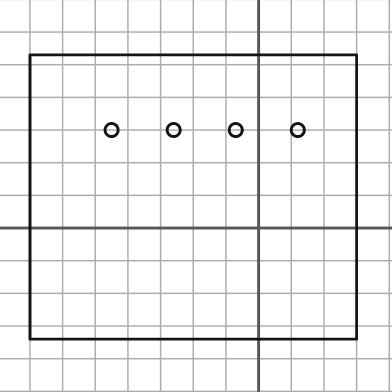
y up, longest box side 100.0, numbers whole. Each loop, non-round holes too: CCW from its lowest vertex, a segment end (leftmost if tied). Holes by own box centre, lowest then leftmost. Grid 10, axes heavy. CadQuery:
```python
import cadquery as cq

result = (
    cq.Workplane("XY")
    .moveTo(-70.0, -34.0)
    .lineTo(30.0, -34.0)
    .lineTo(30.0, 53.0)
    .lineTo(-70.0, 53.0)
    .close()
    .moveTo(-45.0, 30.0)
    .circle(2.0)
    .moveTo(-26.0, 30.0)
    .circle(2.0)
    .moveTo(-7.0, 30.0)
    .circle(2.0)
    .moveTo(12.0, 30.0)
    .circle(2.0)
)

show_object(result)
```